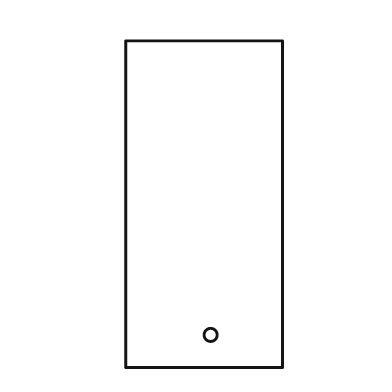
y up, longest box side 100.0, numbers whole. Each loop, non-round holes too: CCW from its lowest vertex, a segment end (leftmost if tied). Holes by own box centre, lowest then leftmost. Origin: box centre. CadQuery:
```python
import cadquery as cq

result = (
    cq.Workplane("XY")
    .moveTo(-24.0, -50.0)
    .lineTo(24.0, -50.0)
    .lineTo(24.0, 50.0)
    .lineTo(-24.0, 50.0)
    .close()
    .moveTo(2.0, -40.0)
    .circle(2.0)
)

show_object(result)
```